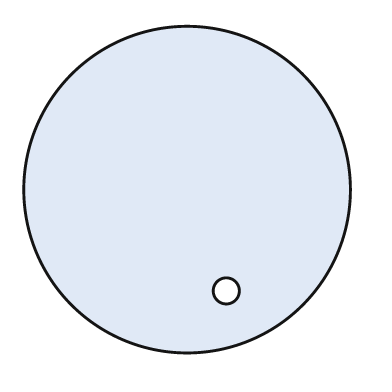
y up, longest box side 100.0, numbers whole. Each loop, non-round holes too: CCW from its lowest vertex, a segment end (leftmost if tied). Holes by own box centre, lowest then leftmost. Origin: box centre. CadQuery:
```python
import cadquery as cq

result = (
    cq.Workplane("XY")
    .moveTo(0.0, 0.0)
    .circle(50.0)
    .moveTo(12.0, -31.0)
    .circle(4.0)
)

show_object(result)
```